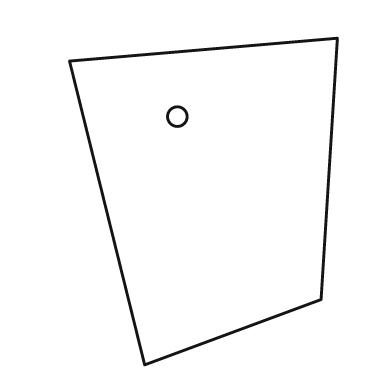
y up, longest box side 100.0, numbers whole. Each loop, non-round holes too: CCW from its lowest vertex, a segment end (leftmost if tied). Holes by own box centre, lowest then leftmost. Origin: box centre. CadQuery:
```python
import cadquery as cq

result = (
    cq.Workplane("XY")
    .moveTo(-18.0, -50.0)
    .lineTo(36.0, -30.0)
    .lineTo(41.0, 50.0)
    .lineTo(-41.0, 43.0)
    .close()
    .moveTo(-8.0, 26.0)
    .circle(3.0)
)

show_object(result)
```